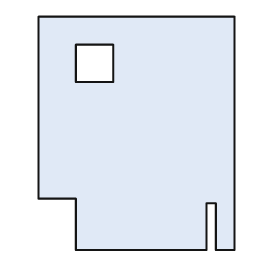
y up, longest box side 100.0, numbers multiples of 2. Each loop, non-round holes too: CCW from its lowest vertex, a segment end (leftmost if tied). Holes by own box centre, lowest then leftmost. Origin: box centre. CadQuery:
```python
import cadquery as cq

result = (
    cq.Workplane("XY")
    .moveTo(-26.0, -50.0)
    .lineTo(30.0, -50.0)
    .lineTo(30.0, -30.0)
    .lineTo(34.0, -30.0)
    .lineTo(34.0, -50.0)
    .lineTo(42.0, -50.0)
    .lineTo(42.0, 50.0)
    .lineTo(-42.0, 50.0)
    .lineTo(-42.0, -28.0)
    .lineTo(-26.0, -28.0)
    .close()
    .moveTo(-26.0, 22.0)
    .lineTo(-10.0, 22.0)
    .lineTo(-10.0, 38.0)
    .lineTo(-26.0, 38.0)
    .close()
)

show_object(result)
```